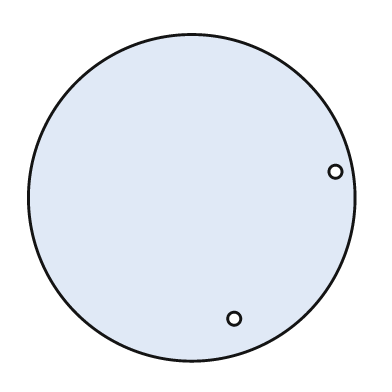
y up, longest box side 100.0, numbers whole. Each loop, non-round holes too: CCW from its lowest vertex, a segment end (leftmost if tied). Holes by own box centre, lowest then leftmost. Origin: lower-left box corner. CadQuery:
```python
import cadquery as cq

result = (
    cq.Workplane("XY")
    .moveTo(50.0, 50.0)
    .circle(50.0)
    .moveTo(63.0, 13.0)
    .circle(2.0)
    .moveTo(94.0, 58.0)
    .circle(2.0)
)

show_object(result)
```